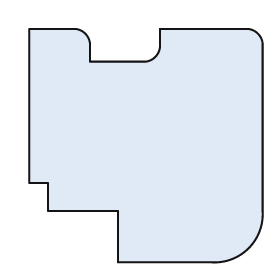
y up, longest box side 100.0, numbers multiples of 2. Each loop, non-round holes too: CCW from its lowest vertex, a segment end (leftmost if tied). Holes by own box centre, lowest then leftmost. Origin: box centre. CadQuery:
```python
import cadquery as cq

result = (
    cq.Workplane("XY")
    .moveTo(-12.0, -50.0)
    .lineTo(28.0, -50.0)
    .threePointArc((44.0, -44.0), (50.0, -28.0))
    .lineTo(50.0, 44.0)
    .threePointArc((48.0, 48.0), (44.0, 50.0))
    .lineTo(6.0, 50.0)
    .lineTo(6.0, 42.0)
    .threePointArc((4.0, 38.0), (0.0, 36.0))
    .lineTo(-24.0, 36.0)
    .lineTo(-24.0, 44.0)
    .threePointArc((-26.0, 48.0), (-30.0, 50.0))
    .lineTo(-50.0, 50.0)
    .lineTo(-50.0, -16.0)
    .lineTo(-42.0, -16.0)
    .lineTo(-42.0, -28.0)
    .lineTo(-12.0, -28.0)
    .close()
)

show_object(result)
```